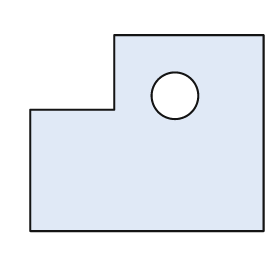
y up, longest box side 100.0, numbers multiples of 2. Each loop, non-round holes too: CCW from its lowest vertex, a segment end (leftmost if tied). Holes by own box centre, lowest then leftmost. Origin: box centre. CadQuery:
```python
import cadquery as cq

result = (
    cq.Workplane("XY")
    .moveTo(-50.0, -42.0)
    .lineTo(50.0, -42.0)
    .lineTo(50.0, 42.0)
    .lineTo(-14.0, 42.0)
    .lineTo(-14.0, 10.0)
    .lineTo(-50.0, 10.0)
    .close()
    .moveTo(12.0, 16.0)
    .circle(10.0)
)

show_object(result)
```